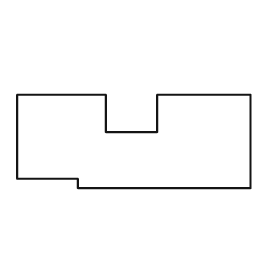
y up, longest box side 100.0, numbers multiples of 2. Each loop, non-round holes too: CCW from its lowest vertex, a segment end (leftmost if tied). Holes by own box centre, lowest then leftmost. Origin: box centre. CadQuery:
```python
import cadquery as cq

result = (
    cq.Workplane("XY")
    .moveTo(-24.0, -20.0)
    .lineTo(50.0, -20.0)
    .lineTo(50.0, 20.0)
    .lineTo(10.0, 20.0)
    .lineTo(10.0, 4.0)
    .lineTo(-12.0, 4.0)
    .lineTo(-12.0, 20.0)
    .lineTo(-50.0, 20.0)
    .lineTo(-50.0, -16.0)
    .lineTo(-24.0, -16.0)
    .close()
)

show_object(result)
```